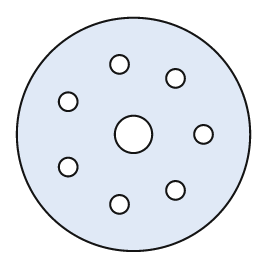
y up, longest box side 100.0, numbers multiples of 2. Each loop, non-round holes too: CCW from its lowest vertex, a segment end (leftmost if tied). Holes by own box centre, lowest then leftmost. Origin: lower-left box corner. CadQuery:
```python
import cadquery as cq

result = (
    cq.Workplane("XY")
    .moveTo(50.0, 50.0)
    .circle(50.0)
    .moveTo(44.0, 20.0)
    .circle(4.0)
    .moveTo(68.0, 26.0)
    .circle(4.0)
    .moveTo(22.0, 36.0)
    .circle(4.0)
    .moveTo(50.0, 50.0)
    .circle(8.0)
    .moveTo(80.0, 50.0)
    .circle(4.0)
    .moveTo(22.0, 64.0)
    .circle(4.0)
    .moveTo(68.0, 74.0)
    .circle(4.0)
    .moveTo(44.0, 80.0)
    .circle(4.0)
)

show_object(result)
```